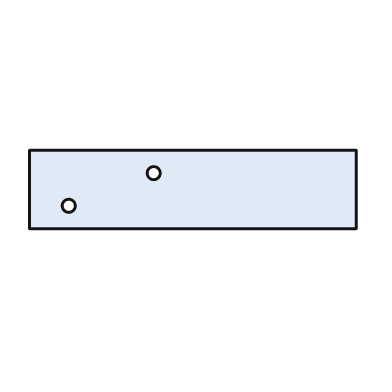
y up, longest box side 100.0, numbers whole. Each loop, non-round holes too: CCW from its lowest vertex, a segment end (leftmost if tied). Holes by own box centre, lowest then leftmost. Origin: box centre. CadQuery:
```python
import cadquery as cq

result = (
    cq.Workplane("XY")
    .moveTo(-50.0, -12.0)
    .lineTo(50.0, -12.0)
    .lineTo(50.0, 12.0)
    .lineTo(-50.0, 12.0)
    .close()
    .moveTo(-38.0, -5.0)
    .circle(2.0)
    .moveTo(-12.0, 5.0)
    .circle(2.0)
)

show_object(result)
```